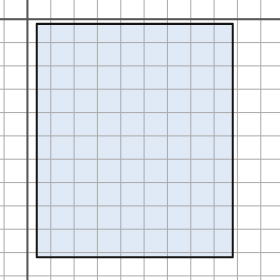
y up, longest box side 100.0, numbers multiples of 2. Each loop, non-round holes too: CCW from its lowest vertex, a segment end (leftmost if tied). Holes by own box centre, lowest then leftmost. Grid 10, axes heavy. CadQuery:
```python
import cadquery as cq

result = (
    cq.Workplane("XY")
    .moveTo(4.0, -102.0)
    .lineTo(88.0, -102.0)
    .lineTo(88.0, -2.0)
    .lineTo(4.0, -2.0)
    .close()
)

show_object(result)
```